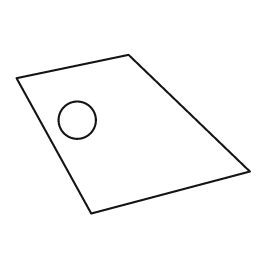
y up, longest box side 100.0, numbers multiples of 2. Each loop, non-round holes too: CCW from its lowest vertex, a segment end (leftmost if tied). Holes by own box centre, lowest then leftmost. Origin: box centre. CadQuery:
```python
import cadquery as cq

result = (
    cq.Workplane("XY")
    .moveTo(-18.0, -34.0)
    .lineTo(50.0, -16.0)
    .lineTo(-2.0, 34.0)
    .lineTo(-50.0, 24.0)
    .close()
    .moveTo(-24.0, 6.0)
    .circle(8.0)
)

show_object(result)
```